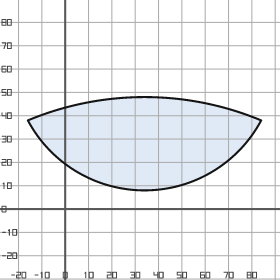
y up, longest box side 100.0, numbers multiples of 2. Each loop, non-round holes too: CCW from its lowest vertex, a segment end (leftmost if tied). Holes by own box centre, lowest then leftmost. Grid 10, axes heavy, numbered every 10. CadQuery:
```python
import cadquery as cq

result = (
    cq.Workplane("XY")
    .moveTo(-16.0, 38.0)
    .threePointArc((34.0, 8.0), (84.0, 38.0))
    .threePointArc((34.0, 48.0), (-16.0, 38.0))
    .close()
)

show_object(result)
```